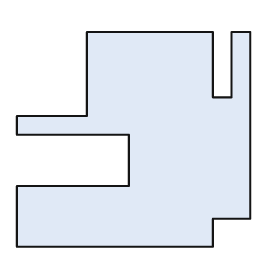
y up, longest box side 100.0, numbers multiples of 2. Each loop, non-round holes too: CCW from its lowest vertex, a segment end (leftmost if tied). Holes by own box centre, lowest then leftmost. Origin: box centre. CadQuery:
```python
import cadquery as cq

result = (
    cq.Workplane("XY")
    .moveTo(-50.0, -46.0)
    .lineTo(34.0, -46.0)
    .lineTo(34.0, -34.0)
    .lineTo(50.0, -34.0)
    .lineTo(50.0, 46.0)
    .lineTo(42.0, 46.0)
    .lineTo(42.0, 18.0)
    .lineTo(34.0, 18.0)
    .lineTo(34.0, 46.0)
    .lineTo(-20.0, 46.0)
    .lineTo(-20.0, 10.0)
    .lineTo(-50.0, 10.0)
    .lineTo(-50.0, 2.0)
    .lineTo(-2.0, 2.0)
    .lineTo(-2.0, -20.0)
    .lineTo(-50.0, -20.0)
    .close()
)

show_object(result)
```